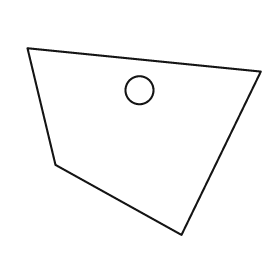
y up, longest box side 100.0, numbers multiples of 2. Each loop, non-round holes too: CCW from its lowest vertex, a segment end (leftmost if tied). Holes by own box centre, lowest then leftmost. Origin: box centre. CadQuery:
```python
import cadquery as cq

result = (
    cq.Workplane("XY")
    .moveTo(16.0, -40.0)
    .lineTo(50.0, 30.0)
    .lineTo(-50.0, 40.0)
    .lineTo(-38.0, -10.0)
    .close()
    .moveTo(-2.0, 22.0)
    .circle(6.0)
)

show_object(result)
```